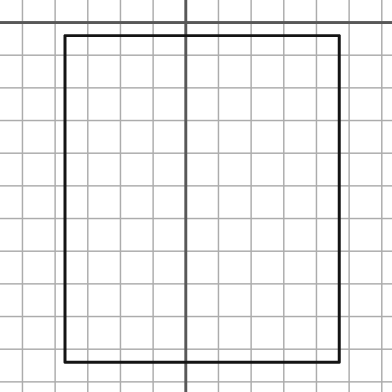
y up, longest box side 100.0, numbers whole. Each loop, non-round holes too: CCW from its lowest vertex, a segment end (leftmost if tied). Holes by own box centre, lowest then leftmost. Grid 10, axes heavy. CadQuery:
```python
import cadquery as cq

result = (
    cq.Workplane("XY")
    .moveTo(-37.0, -104.0)
    .lineTo(47.0, -104.0)
    .lineTo(47.0, -4.0)
    .lineTo(-37.0, -4.0)
    .close()
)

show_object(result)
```